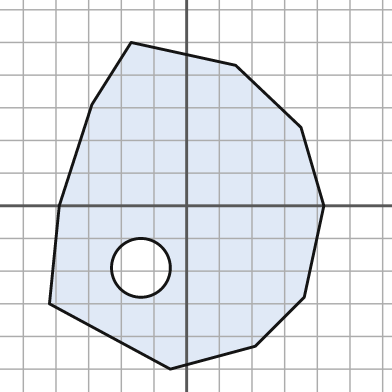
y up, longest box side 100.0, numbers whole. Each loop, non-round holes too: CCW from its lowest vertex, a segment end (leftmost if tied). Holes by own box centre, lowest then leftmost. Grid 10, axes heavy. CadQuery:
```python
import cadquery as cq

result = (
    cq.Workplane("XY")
    .moveTo(-5.0, -50.0)
    .lineTo(21.0, -43.0)
    .lineTo(36.0, -28.0)
    .lineTo(42.0, 0.0)
    .lineTo(35.0, 24.0)
    .lineTo(15.0, 43.0)
    .lineTo(-17.0, 50.0)
    .lineTo(-29.0, 31.0)
    .lineTo(-39.0, 0.0)
    .lineTo(-42.0, -30.0)
    .close()
    .moveTo(-14.0, -19.0)
    .circle(9.0)
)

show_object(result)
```